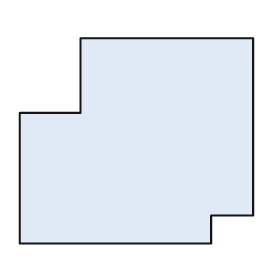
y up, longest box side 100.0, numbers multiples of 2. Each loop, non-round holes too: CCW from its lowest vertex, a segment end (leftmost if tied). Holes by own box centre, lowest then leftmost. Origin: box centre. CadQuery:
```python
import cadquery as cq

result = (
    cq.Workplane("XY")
    .moveTo(-50.0, -44.0)
    .lineTo(32.0, -44.0)
    .lineTo(32.0, -32.0)
    .lineTo(50.0, -32.0)
    .lineTo(50.0, 44.0)
    .lineTo(-24.0, 44.0)
    .lineTo(-24.0, 12.0)
    .lineTo(-50.0, 12.0)
    .close()
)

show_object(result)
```